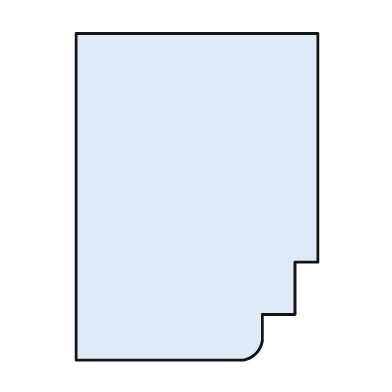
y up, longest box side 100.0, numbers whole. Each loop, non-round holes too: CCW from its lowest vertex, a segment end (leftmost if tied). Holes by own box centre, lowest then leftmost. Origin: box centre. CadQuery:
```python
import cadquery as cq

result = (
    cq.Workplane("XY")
    .moveTo(-37.0, -50.0)
    .lineTo(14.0, -50.0)
    .threePointArc((18.0, -48.0), (20.0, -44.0))
    .lineTo(20.0, -36.0)
    .lineTo(30.0, -36.0)
    .lineTo(30.0, -20.0)
    .lineTo(37.0, -20.0)
    .lineTo(37.0, 50.0)
    .lineTo(-37.0, 50.0)
    .close()
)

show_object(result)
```